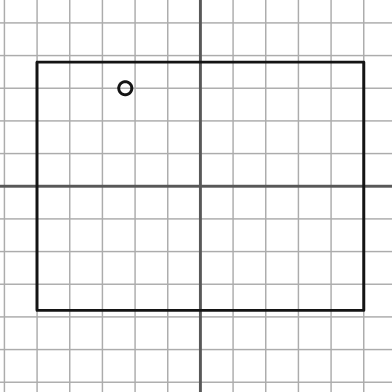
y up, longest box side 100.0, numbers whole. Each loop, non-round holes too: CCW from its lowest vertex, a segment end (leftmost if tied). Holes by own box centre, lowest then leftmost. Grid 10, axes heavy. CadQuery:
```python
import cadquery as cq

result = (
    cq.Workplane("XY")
    .moveTo(-50.0, -38.0)
    .lineTo(50.0, -38.0)
    .lineTo(50.0, 38.0)
    .lineTo(-50.0, 38.0)
    .close()
    .moveTo(-23.0, 30.0)
    .circle(2.0)
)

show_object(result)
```